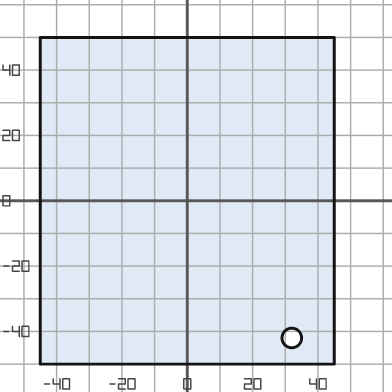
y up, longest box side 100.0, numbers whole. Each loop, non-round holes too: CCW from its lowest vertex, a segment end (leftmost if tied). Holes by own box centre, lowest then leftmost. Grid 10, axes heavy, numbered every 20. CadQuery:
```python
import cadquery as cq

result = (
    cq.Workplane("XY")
    .moveTo(-45.0, -50.0)
    .lineTo(45.0, -50.0)
    .lineTo(45.0, 50.0)
    .lineTo(-45.0, 50.0)
    .close()
    .moveTo(32.0, -42.0)
    .circle(3.0)
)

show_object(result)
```